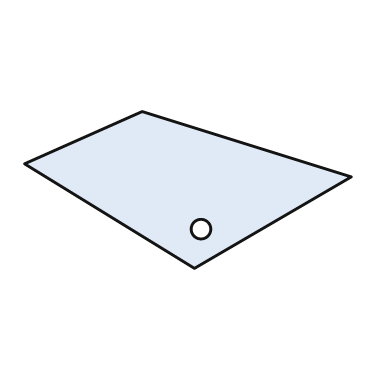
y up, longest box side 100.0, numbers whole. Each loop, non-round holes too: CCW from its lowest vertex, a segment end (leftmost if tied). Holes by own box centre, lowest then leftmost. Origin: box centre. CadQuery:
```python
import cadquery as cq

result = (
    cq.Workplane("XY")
    .moveTo(2.0, -24.0)
    .lineTo(50.0, 4.0)
    .lineTo(-14.0, 24.0)
    .lineTo(-50.0, 8.0)
    .close()
    .moveTo(4.0, -12.0)
    .circle(3.0)
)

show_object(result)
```